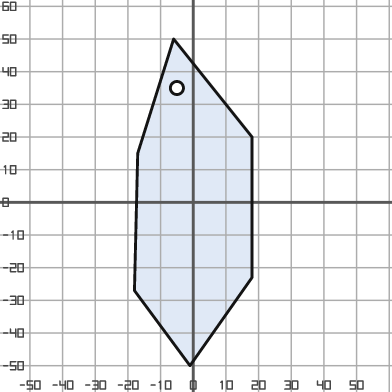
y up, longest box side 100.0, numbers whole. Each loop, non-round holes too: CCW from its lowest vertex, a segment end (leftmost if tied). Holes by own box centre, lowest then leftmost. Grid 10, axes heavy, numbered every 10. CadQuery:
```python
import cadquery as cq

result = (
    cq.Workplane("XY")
    .moveTo(-1.0, -50.0)
    .lineTo(18.0, -23.0)
    .lineTo(18.0, 20.0)
    .lineTo(-6.0, 50.0)
    .lineTo(-17.0, 15.0)
    .lineTo(-18.0, -27.0)
    .close()
    .moveTo(-5.0, 35.0)
    .circle(2.0)
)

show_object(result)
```